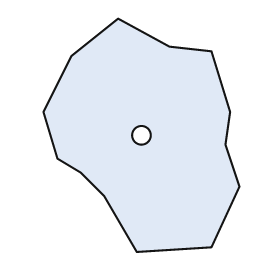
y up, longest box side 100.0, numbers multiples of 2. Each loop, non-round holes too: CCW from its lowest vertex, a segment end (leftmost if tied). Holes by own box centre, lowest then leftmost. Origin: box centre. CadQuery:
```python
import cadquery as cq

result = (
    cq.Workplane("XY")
    .moveTo(-2.0, -50.0)
    .lineTo(30.0, -48.0)
    .lineTo(42.0, -22.0)
    .lineTo(36.0, -4.0)
    .lineTo(38.0, 10.0)
    .lineTo(30.0, 36.0)
    .lineTo(12.0, 38.0)
    .lineTo(-10.0, 50.0)
    .lineTo(-30.0, 34.0)
    .lineTo(-42.0, 10.0)
    .lineTo(-36.0, -10.0)
    .lineTo(-26.0, -16.0)
    .lineTo(-16.0, -26.0)
    .close()
    .moveTo(0.0, 0.0)
    .circle(4.0)
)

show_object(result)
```